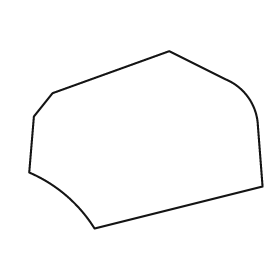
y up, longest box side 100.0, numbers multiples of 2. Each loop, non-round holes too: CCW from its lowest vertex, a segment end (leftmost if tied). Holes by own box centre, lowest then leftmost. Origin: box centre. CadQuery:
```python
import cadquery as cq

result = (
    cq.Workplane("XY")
    .moveTo(-22.0, -38.0)
    .lineTo(50.0, -20.0)
    .lineTo(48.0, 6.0)
    .threePointArc((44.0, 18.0), (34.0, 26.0))
    .lineTo(10.0, 38.0)
    .lineTo(-40.0, 20.0)
    .lineTo(-48.0, 10.0)
    .lineTo(-50.0, -14.0)
    .threePointArc((-34.0, -24.0), (-22.0, -38.0))
    .close()
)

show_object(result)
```